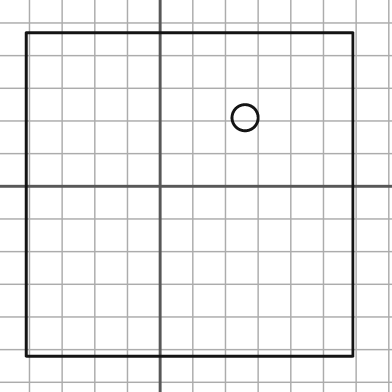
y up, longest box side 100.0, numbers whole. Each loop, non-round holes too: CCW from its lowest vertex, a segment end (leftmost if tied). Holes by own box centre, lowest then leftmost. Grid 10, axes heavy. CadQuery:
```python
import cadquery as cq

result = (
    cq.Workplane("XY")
    .moveTo(-41.0, -52.0)
    .lineTo(59.0, -52.0)
    .lineTo(59.0, 47.0)
    .lineTo(-41.0, 47.0)
    .close()
    .moveTo(26.0, 21.0)
    .circle(4.0)
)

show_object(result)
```